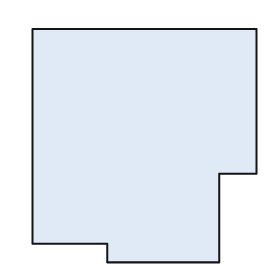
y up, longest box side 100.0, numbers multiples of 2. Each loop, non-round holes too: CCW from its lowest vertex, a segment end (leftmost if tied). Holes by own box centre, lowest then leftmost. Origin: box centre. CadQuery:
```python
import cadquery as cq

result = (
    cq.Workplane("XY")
    .moveTo(-16.0, -50.0)
    .lineTo(32.0, -50.0)
    .lineTo(32.0, -12.0)
    .lineTo(48.0, -12.0)
    .lineTo(48.0, 50.0)
    .lineTo(-48.0, 50.0)
    .lineTo(-48.0, -42.0)
    .lineTo(-16.0, -42.0)
    .close()
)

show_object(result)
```